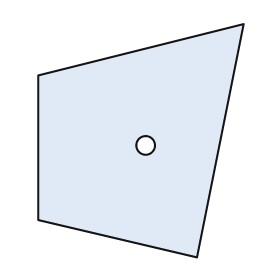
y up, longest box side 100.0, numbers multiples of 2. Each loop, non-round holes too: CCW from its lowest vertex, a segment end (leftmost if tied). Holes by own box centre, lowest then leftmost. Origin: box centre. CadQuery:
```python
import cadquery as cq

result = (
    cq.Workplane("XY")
    .moveTo(24.0, -50.0)
    .lineTo(44.0, 50.0)
    .lineTo(-44.0, 28.0)
    .lineTo(-44.0, -34.0)
    .close()
    .moveTo(2.0, -2.0)
    .circle(4.0)
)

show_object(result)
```